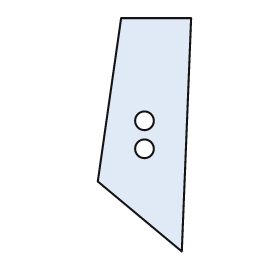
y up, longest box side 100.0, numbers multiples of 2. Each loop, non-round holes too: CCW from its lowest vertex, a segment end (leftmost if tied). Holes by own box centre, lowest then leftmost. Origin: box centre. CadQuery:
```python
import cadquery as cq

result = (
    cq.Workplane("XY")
    .moveTo(16.0, -50.0)
    .lineTo(20.0, 50.0)
    .lineTo(-10.0, 50.0)
    .lineTo(-20.0, -20.0)
    .close()
    .moveTo(0.0, -6.0)
    .circle(4.0)
    .moveTo(0.0, 6.0)
    .circle(4.0)
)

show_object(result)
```